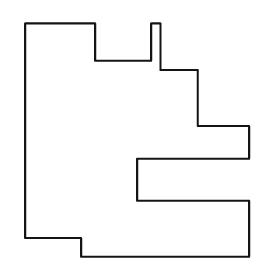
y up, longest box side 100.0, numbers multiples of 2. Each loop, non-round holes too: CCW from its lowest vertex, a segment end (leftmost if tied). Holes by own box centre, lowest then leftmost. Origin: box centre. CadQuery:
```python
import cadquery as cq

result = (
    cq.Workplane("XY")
    .moveTo(-24.0, -50.0)
    .lineTo(48.0, -50.0)
    .lineTo(48.0, -26.0)
    .lineTo(0.0, -26.0)
    .lineTo(0.0, -8.0)
    .lineTo(48.0, -8.0)
    .lineTo(48.0, 6.0)
    .lineTo(26.0, 6.0)
    .lineTo(26.0, 30.0)
    .lineTo(10.0, 30.0)
    .lineTo(10.0, 50.0)
    .lineTo(6.0, 50.0)
    .lineTo(6.0, 34.0)
    .lineTo(-18.0, 34.0)
    .lineTo(-18.0, 50.0)
    .lineTo(-48.0, 50.0)
    .lineTo(-48.0, -42.0)
    .lineTo(-24.0, -42.0)
    .close()
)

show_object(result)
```